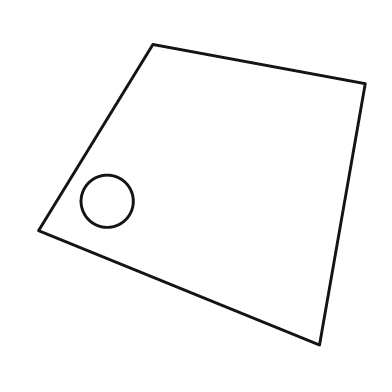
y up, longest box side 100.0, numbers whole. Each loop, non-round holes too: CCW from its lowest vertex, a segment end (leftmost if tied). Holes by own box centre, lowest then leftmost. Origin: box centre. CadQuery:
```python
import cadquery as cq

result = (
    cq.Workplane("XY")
    .moveTo(36.0, -46.0)
    .lineTo(50.0, 34.0)
    .lineTo(-15.0, 46.0)
    .lineTo(-50.0, -11.0)
    .close()
    .moveTo(-29.0, -2.0)
    .circle(8.0)
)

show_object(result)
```